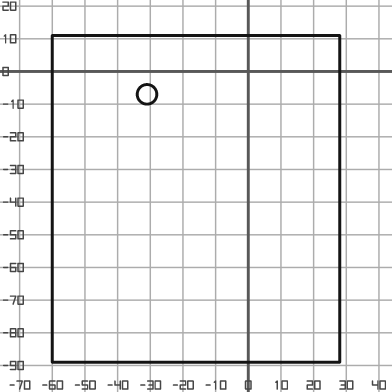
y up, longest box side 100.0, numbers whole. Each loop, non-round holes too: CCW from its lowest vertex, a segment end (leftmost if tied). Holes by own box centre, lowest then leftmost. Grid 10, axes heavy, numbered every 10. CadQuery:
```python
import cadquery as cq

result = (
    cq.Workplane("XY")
    .moveTo(-60.0, -89.0)
    .lineTo(28.0, -89.0)
    .lineTo(28.0, 11.0)
    .lineTo(-60.0, 11.0)
    .close()
    .moveTo(-31.0, -7.0)
    .circle(3.0)
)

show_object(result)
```